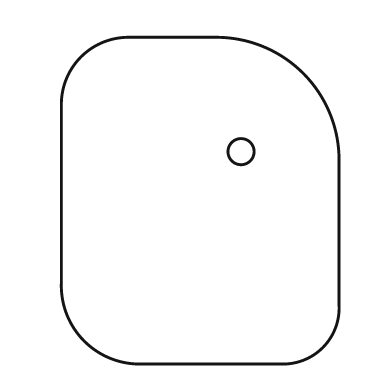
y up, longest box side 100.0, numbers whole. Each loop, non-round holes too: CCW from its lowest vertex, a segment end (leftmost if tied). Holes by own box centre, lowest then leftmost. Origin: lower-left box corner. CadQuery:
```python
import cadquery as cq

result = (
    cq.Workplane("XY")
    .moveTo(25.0, 0.0)
    .lineTo(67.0, 0.0)
    .threePointArc((80.0, 5.0), (85.0, 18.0))
    .lineTo(85.0, 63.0)
    .threePointArc((74.0, 89.0), (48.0, 100.0))
    .lineTo(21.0, 100.0)
    .threePointArc((6.0, 94.0), (0.0, 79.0))
    .lineTo(0.0, 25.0)
    .threePointArc((7.0, 7.0), (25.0, 0.0))
    .close()
    .moveTo(55.0, 65.0)
    .circle(4.0)
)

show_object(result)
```